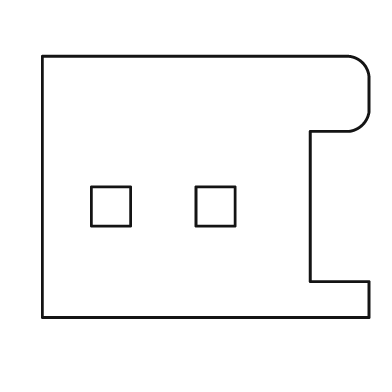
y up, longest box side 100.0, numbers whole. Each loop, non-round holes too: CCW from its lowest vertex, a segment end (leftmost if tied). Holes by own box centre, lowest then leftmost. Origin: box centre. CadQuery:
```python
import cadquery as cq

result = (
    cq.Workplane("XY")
    .moveTo(-50.0, -40.0)
    .lineTo(50.0, -40.0)
    .lineTo(50.0, -29.0)
    .lineTo(32.0, -29.0)
    .lineTo(32.0, 17.0)
    .lineTo(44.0, 17.0)
    .threePointArc((48.0, 19.0), (50.0, 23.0))
    .lineTo(50.0, 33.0)
    .threePointArc((48.0, 38.0), (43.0, 40.0))
    .lineTo(-50.0, 40.0)
    .close()
    .moveTo(-35.0, -12.0)
    .lineTo(-23.0, -12.0)
    .lineTo(-23.0, 0.0)
    .lineTo(-35.0, 0.0)
    .close()
    .moveTo(-3.0, -12.0)
    .lineTo(9.0, -12.0)
    .lineTo(9.0, 0.0)
    .lineTo(-3.0, 0.0)
    .close()
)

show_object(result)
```